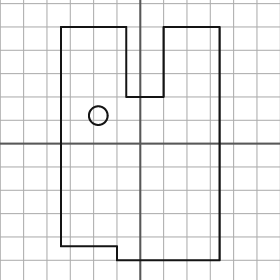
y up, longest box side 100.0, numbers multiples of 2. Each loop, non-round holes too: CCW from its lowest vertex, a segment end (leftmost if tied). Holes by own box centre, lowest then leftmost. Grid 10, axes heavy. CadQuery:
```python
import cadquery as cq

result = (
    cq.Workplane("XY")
    .moveTo(-10.0, -50.0)
    .lineTo(34.0, -50.0)
    .lineTo(34.0, 50.0)
    .lineTo(10.0, 50.0)
    .lineTo(10.0, 20.0)
    .lineTo(-6.0, 20.0)
    .lineTo(-6.0, 50.0)
    .lineTo(-34.0, 50.0)
    .lineTo(-34.0, -44.0)
    .lineTo(-10.0, -44.0)
    .close()
    .moveTo(-18.0, 12.0)
    .circle(4.0)
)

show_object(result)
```